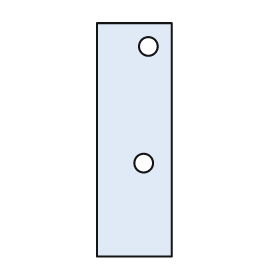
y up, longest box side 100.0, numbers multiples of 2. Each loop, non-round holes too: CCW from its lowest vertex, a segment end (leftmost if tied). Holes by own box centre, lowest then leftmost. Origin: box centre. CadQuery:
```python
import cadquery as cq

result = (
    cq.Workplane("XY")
    .moveTo(-16.0, -50.0)
    .lineTo(16.0, -50.0)
    .lineTo(16.0, 50.0)
    .lineTo(-16.0, 50.0)
    .close()
    .moveTo(4.0, -10.0)
    .circle(4.0)
    .moveTo(6.0, 40.0)
    .circle(4.0)
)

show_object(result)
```